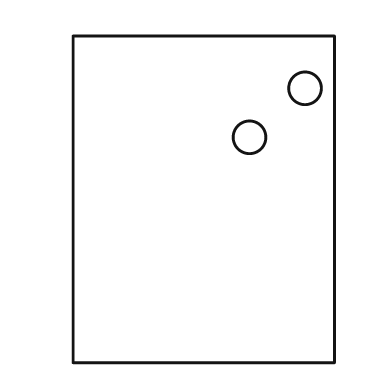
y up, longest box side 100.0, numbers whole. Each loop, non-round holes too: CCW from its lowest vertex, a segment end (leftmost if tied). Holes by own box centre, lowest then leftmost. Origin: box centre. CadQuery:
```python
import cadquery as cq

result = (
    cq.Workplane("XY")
    .moveTo(-40.0, -50.0)
    .lineTo(40.0, -50.0)
    .lineTo(40.0, 50.0)
    .lineTo(-40.0, 50.0)
    .close()
    .moveTo(14.0, 19.0)
    .circle(5.0)
    .moveTo(31.0, 34.0)
    .circle(5.0)
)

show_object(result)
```